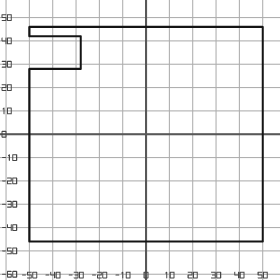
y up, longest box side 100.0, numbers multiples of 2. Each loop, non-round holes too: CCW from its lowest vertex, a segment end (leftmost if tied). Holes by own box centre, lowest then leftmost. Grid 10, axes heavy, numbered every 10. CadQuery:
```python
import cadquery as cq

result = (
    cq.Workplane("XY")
    .moveTo(-50.0, -46.0)
    .lineTo(50.0, -46.0)
    .lineTo(50.0, 46.0)
    .lineTo(-50.0, 46.0)
    .lineTo(-50.0, 42.0)
    .lineTo(-28.0, 42.0)
    .lineTo(-28.0, 28.0)
    .lineTo(-50.0, 28.0)
    .close()
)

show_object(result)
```